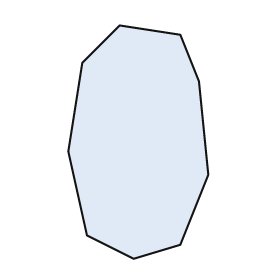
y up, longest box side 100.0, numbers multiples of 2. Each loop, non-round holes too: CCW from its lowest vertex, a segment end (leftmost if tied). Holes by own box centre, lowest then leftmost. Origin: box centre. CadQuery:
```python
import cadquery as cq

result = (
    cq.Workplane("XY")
    .moveTo(-2.0, -50.0)
    .lineTo(18.0, -44.0)
    .lineTo(30.0, -14.0)
    .lineTo(26.0, 26.0)
    .lineTo(18.0, 46.0)
    .lineTo(-8.0, 50.0)
    .lineTo(-24.0, 34.0)
    .lineTo(-30.0, -4.0)
    .lineTo(-22.0, -40.0)
    .close()
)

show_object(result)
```